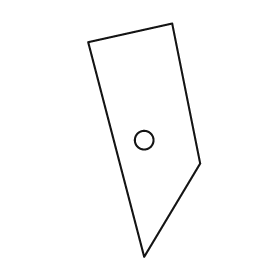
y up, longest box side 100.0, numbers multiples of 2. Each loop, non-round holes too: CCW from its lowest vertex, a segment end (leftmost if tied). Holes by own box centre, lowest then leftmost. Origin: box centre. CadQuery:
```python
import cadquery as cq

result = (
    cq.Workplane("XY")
    .moveTo(0.0, -50.0)
    .lineTo(24.0, -10.0)
    .lineTo(12.0, 50.0)
    .lineTo(-24.0, 42.0)
    .close()
    .moveTo(0.0, 0.0)
    .circle(4.0)
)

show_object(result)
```